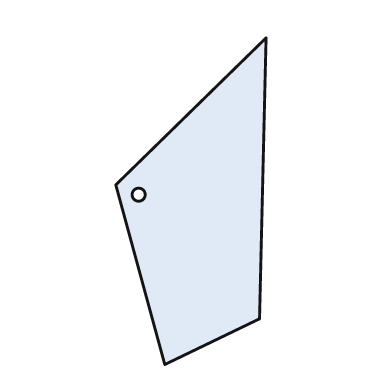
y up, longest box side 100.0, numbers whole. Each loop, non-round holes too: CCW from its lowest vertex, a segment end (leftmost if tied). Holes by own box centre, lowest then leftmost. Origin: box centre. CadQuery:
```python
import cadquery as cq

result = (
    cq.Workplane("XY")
    .moveTo(-8.0, -50.0)
    .lineTo(21.0, -36.0)
    .lineTo(23.0, 50.0)
    .lineTo(-23.0, 5.0)
    .close()
    .moveTo(-16.0, 2.0)
    .circle(2.0)
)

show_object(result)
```